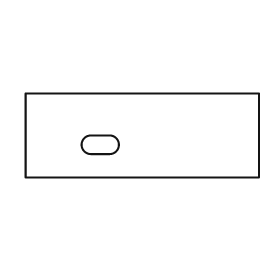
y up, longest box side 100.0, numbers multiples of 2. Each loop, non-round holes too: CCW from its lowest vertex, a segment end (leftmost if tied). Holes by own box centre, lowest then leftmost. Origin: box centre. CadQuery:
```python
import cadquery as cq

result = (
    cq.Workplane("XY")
    .moveTo(-50.0, -18.0)
    .lineTo(50.0, -18.0)
    .lineTo(50.0, 18.0)
    .lineTo(-50.0, 18.0)
    .close()
    .moveTo(-22.0, -8.0)
    .lineTo(-14.0, -8.0)
    .threePointArc((-10.0, -4.0), (-14.0, 0.0))
    .lineTo(-22.0, 0.0)
    .threePointArc((-26.0, -4.0), (-22.0, -8.0))
    .close()
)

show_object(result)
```